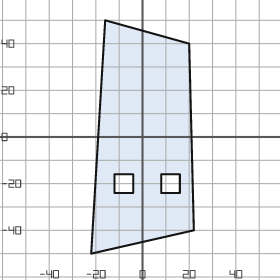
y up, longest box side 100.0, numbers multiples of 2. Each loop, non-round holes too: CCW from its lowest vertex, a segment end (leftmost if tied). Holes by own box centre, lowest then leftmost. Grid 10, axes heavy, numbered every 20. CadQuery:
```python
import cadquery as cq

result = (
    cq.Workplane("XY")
    .moveTo(-22.0, -50.0)
    .lineTo(22.0, -40.0)
    .lineTo(20.0, 40.0)
    .lineTo(-16.0, 50.0)
    .close()
    .moveTo(-12.0, -24.0)
    .lineTo(-4.0, -24.0)
    .lineTo(-4.0, -16.0)
    .lineTo(-12.0, -16.0)
    .close()
    .moveTo(8.0, -24.0)
    .lineTo(16.0, -24.0)
    .lineTo(16.0, -16.0)
    .lineTo(8.0, -16.0)
    .close()
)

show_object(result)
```